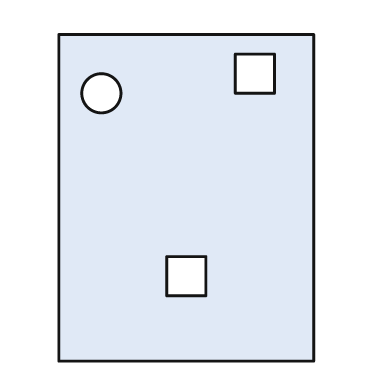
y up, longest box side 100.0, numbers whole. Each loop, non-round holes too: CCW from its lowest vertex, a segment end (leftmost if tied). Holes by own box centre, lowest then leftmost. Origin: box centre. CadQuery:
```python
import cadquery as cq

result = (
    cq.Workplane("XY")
    .moveTo(-39.0, -50.0)
    .lineTo(39.0, -50.0)
    .lineTo(39.0, 50.0)
    .lineTo(-39.0, 50.0)
    .close()
    .moveTo(-6.0, -30.0)
    .lineTo(6.0, -30.0)
    .lineTo(6.0, -18.0)
    .lineTo(-6.0, -18.0)
    .close()
    .moveTo(-26.0, 32.0)
    .circle(6.0)
    .moveTo(15.0, 32.0)
    .lineTo(27.0, 32.0)
    .lineTo(27.0, 44.0)
    .lineTo(15.0, 44.0)
    .close()
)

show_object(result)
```